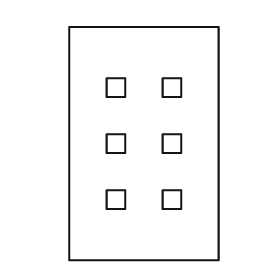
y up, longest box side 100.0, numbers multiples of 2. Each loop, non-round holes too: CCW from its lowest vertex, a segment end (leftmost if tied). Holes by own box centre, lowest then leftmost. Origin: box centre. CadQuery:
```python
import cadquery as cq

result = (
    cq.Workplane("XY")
    .moveTo(-32.0, -50.0)
    .lineTo(32.0, -50.0)
    .lineTo(32.0, 50.0)
    .lineTo(-32.0, 50.0)
    .close()
    .moveTo(-16.0, -28.0)
    .lineTo(-8.0, -28.0)
    .lineTo(-8.0, -20.0)
    .lineTo(-16.0, -20.0)
    .close()
    .moveTo(8.0, -28.0)
    .lineTo(16.0, -28.0)
    .lineTo(16.0, -20.0)
    .lineTo(8.0, -20.0)
    .close()
    .moveTo(-16.0, -4.0)
    .lineTo(-8.0, -4.0)
    .lineTo(-8.0, 4.0)
    .lineTo(-16.0, 4.0)
    .close()
    .moveTo(8.0, -4.0)
    .lineTo(16.0, -4.0)
    .lineTo(16.0, 4.0)
    .lineTo(8.0, 4.0)
    .close()
    .moveTo(-16.0, 20.0)
    .lineTo(-8.0, 20.0)
    .lineTo(-8.0, 28.0)
    .lineTo(-16.0, 28.0)
    .close()
    .moveTo(8.0, 20.0)
    .lineTo(16.0, 20.0)
    .lineTo(16.0, 28.0)
    .lineTo(8.0, 28.0)
    .close()
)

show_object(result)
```